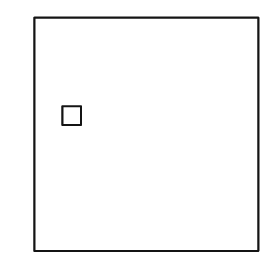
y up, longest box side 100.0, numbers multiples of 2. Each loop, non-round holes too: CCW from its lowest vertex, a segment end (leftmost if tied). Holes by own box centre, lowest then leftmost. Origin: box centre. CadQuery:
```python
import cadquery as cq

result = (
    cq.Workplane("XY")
    .moveTo(-48.0, -50.0)
    .lineTo(48.0, -50.0)
    .lineTo(48.0, 50.0)
    .lineTo(-48.0, 50.0)
    .close()
    .moveTo(-36.0, 4.0)
    .lineTo(-28.0, 4.0)
    .lineTo(-28.0, 12.0)
    .lineTo(-36.0, 12.0)
    .close()
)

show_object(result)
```